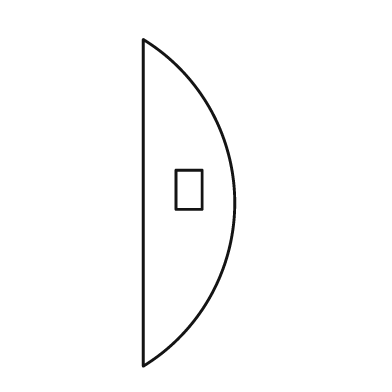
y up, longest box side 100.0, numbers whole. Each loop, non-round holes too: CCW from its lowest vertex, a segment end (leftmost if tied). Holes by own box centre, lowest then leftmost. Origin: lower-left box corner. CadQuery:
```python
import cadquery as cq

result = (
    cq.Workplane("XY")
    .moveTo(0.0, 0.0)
    .threePointArc((28.0, 50.0), (0.0, 100.0))
    .close()
    .moveTo(10.0, 48.0)
    .lineTo(18.0, 48.0)
    .lineTo(18.0, 60.0)
    .lineTo(10.0, 60.0)
    .close()
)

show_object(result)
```